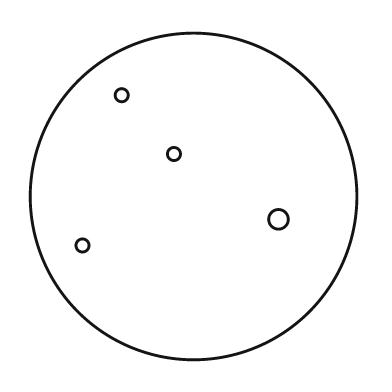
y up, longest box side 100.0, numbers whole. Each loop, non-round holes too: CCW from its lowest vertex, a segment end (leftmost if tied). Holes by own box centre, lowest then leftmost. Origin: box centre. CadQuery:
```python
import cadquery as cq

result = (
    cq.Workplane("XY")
    .moveTo(0.0, 0.0)
    .circle(50.0)
    .moveTo(-34.0, -15.0)
    .circle(2.0)
    .moveTo(26.0, -7.0)
    .circle(3.0)
    .moveTo(-6.0, 13.0)
    .circle(2.0)
    .moveTo(-22.0, 31.0)
    .circle(2.0)
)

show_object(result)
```